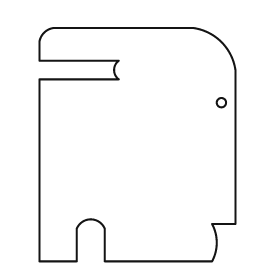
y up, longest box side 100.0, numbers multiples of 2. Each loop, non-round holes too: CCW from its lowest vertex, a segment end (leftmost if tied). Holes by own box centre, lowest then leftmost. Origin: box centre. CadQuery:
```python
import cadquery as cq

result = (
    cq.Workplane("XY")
    .moveTo(-42.0, -50.0)
    .lineTo(-26.0, -50.0)
    .lineTo(-26.0, -36.0)
    .threePointArc((-20.0, -32.0), (-14.0, -36.0))
    .lineTo(-14.0, -50.0)
    .lineTo(32.0, -50.0)
    .threePointArc((34.0, -42.0), (32.0, -34.0))
    .lineTo(42.0, -34.0)
    .lineTo(42.0, 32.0)
    .threePointArc((36.0, 44.0), (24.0, 50.0))
    .lineTo(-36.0, 50.0)
    .threePointArc((-40.0, 48.0), (-42.0, 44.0))
    .lineTo(-42.0, 36.0)
    .lineTo(-8.0, 36.0)
    .threePointArc((-10.0, 32.0), (-8.0, 28.0))
    .lineTo(-42.0, 28.0)
    .close()
    .moveTo(36.0, 18.0)
    .circle(2.0)
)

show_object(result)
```